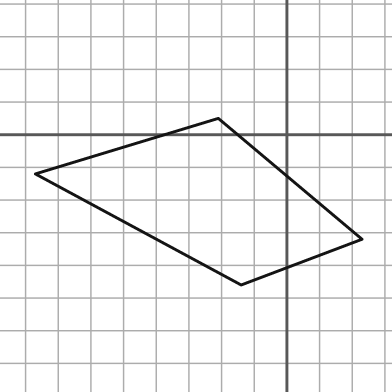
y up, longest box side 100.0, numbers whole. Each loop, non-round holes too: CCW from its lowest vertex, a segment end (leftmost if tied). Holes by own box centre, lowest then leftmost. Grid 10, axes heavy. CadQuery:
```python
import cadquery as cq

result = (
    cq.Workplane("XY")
    .moveTo(-14.0, -46.0)
    .lineTo(23.0, -32.0)
    .lineTo(-21.0, 5.0)
    .lineTo(-77.0, -12.0)
    .close()
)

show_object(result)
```